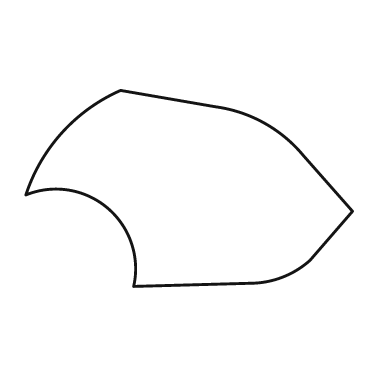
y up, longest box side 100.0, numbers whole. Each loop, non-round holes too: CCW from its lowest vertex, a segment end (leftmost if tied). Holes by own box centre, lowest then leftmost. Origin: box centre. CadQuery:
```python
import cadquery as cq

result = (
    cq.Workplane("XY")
    .moveTo(-17.0, -30.0)
    .lineTo(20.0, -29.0)
    .threePointArc((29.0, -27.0), (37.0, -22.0))
    .lineTo(50.0, -7.0)
    .lineTo(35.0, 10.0)
    .threePointArc((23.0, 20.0), (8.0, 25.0))
    .lineTo(-21.0, 30.0)
    .threePointArc((-39.0, 17.0), (-50.0, -2.0))
    .threePointArc((-25.0, -6.0), (-17.0, -30.0))
    .close()
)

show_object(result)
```